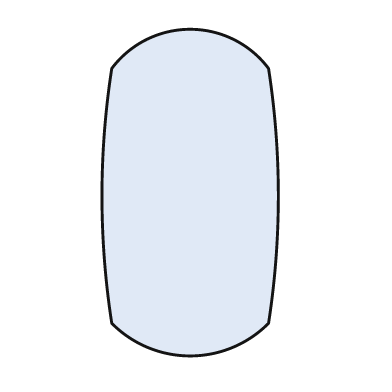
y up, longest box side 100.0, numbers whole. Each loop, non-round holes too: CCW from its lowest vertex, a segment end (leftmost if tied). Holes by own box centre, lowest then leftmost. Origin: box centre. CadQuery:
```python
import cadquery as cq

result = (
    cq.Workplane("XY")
    .moveTo(-24.0, -40.0)
    .threePointArc((0.0, -50.0), (24.0, -40.0))
    .threePointArc((27.0, -1.0), (24.0, 38.0))
    .threePointArc((0.0, 50.0), (-24.0, 38.0))
    .threePointArc((-27.0, -1.0), (-24.0, -40.0))
    .close()
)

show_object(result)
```